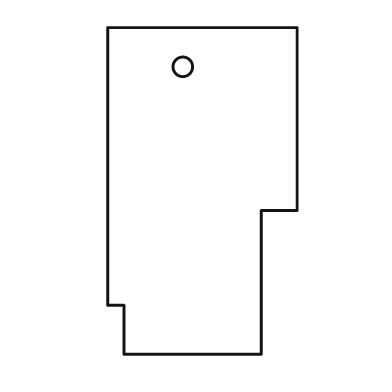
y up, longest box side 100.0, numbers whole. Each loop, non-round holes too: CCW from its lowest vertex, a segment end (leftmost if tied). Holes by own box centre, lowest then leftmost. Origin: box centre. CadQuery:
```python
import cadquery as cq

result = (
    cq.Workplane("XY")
    .moveTo(-24.0, -50.0)
    .lineTo(18.0, -50.0)
    .lineTo(18.0, -6.0)
    .lineTo(29.0, -6.0)
    .lineTo(29.0, 50.0)
    .lineTo(-29.0, 50.0)
    .lineTo(-29.0, -35.0)
    .lineTo(-24.0, -35.0)
    .close()
    .moveTo(-6.0, 38.0)
    .circle(3.0)
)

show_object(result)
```